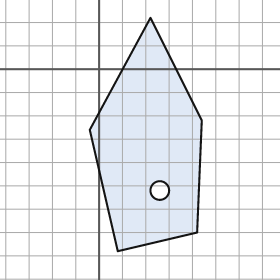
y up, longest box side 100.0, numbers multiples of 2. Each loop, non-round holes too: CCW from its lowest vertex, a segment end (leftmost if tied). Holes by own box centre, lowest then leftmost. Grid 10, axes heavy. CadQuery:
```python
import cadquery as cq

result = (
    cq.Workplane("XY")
    .moveTo(8.0, -78.0)
    .lineTo(42.0, -70.0)
    .lineTo(44.0, -22.0)
    .lineTo(22.0, 22.0)
    .lineTo(-4.0, -26.0)
    .close()
    .moveTo(26.0, -52.0)
    .circle(4.0)
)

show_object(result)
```